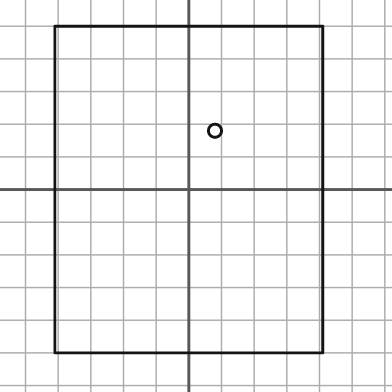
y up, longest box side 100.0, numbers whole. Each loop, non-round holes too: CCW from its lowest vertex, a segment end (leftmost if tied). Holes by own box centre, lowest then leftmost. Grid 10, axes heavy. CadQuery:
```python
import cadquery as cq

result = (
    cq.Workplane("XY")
    .moveTo(-41.0, -50.0)
    .lineTo(41.0, -50.0)
    .lineTo(41.0, 50.0)
    .lineTo(-41.0, 50.0)
    .close()
    .moveTo(8.0, 18.0)
    .circle(2.0)
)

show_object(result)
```